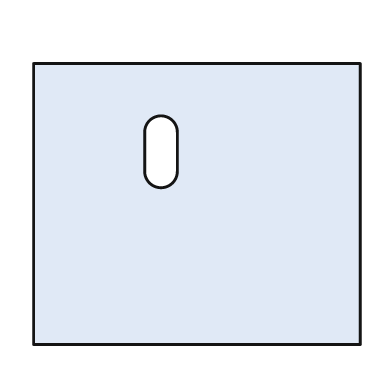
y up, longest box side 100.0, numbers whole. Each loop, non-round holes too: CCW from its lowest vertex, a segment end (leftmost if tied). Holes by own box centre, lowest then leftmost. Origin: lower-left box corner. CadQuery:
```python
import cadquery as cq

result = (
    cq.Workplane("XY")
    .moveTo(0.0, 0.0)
    .lineTo(100.0, 0.0)
    .lineTo(100.0, 86.0)
    .lineTo(0.0, 86.0)
    .close()
    .moveTo(34.0, 53.0)
    .threePointArc((39.0, 48.0), (44.0, 53.0))
    .lineTo(44.0, 65.0)
    .threePointArc((39.0, 70.0), (34.0, 65.0))
    .close()
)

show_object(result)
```